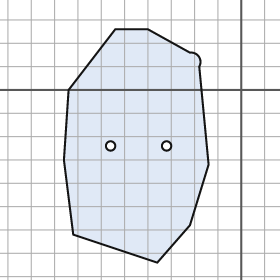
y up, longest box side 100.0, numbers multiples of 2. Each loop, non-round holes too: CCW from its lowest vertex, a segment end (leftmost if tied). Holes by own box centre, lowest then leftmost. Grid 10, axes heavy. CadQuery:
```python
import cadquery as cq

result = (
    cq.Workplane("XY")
    .moveTo(-36.0, -74.0)
    .lineTo(-22.0, -58.0)
    .lineTo(-14.0, -32.0)
    .lineTo(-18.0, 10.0)
    .threePointArc((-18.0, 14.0), (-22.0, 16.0))
    .lineTo(-40.0, 26.0)
    .lineTo(-54.0, 26.0)
    .lineTo(-74.0, 0.0)
    .lineTo(-76.0, -30.0)
    .lineTo(-72.0, -62.0)
    .close()
    .moveTo(-56.0, -24.0)
    .circle(2.0)
    .moveTo(-32.0, -24.0)
    .circle(2.0)
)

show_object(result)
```